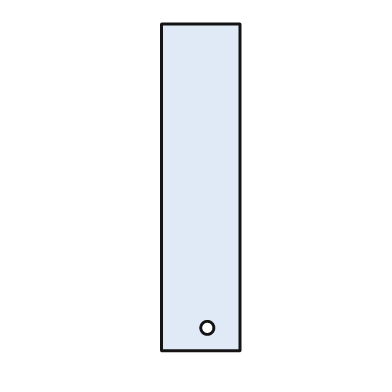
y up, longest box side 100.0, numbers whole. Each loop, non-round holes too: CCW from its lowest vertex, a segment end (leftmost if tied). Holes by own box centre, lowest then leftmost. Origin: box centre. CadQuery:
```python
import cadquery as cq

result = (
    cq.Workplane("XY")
    .moveTo(-12.0, -50.0)
    .lineTo(12.0, -50.0)
    .lineTo(12.0, 50.0)
    .lineTo(-12.0, 50.0)
    .close()
    .moveTo(2.0, -43.0)
    .circle(2.0)
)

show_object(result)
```